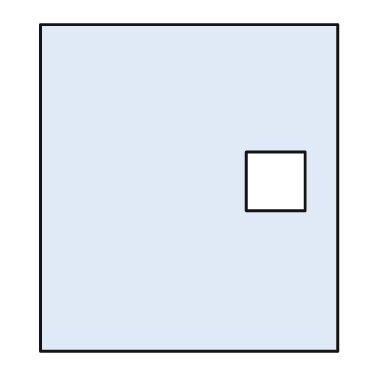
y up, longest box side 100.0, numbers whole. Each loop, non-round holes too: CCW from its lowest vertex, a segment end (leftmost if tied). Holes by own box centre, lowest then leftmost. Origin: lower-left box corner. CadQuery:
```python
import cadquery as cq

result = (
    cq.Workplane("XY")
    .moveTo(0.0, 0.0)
    .lineTo(91.0, 0.0)
    .lineTo(91.0, 100.0)
    .lineTo(0.0, 100.0)
    .close()
    .moveTo(63.0, 43.0)
    .lineTo(81.0, 43.0)
    .lineTo(81.0, 61.0)
    .lineTo(63.0, 61.0)
    .close()
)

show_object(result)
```